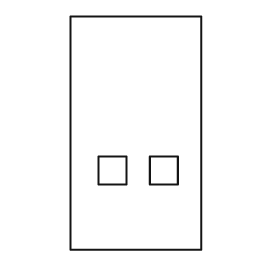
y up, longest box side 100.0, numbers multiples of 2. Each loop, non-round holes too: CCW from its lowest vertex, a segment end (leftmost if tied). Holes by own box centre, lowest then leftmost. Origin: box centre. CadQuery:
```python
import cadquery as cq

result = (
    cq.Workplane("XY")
    .moveTo(-28.0, -50.0)
    .lineTo(28.0, -50.0)
    .lineTo(28.0, 50.0)
    .lineTo(-28.0, 50.0)
    .close()
    .moveTo(-16.0, -22.0)
    .lineTo(-4.0, -22.0)
    .lineTo(-4.0, -10.0)
    .lineTo(-16.0, -10.0)
    .close()
    .moveTo(6.0, -22.0)
    .lineTo(18.0, -22.0)
    .lineTo(18.0, -10.0)
    .lineTo(6.0, -10.0)
    .close()
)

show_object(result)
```